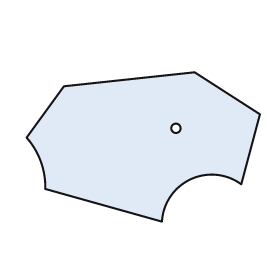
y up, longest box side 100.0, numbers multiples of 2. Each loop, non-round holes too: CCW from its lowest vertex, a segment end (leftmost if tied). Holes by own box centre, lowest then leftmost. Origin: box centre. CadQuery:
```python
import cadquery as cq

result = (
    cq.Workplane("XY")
    .moveTo(8.0, -32.0)
    .threePointArc((20.0, -14.0), (42.0, -16.0))
    .lineTo(50.0, 14.0)
    .lineTo(22.0, 32.0)
    .lineTo(-34.0, 26.0)
    .lineTo(-50.0, 4.0)
    .threePointArc((-44.0, -6.0), (-42.0, -18.0))
    .close()
    .moveTo(14.0, 8.0)
    .circle(2.0)
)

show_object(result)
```